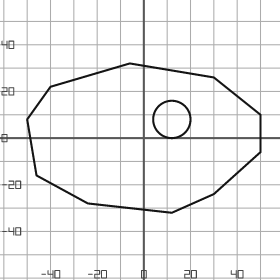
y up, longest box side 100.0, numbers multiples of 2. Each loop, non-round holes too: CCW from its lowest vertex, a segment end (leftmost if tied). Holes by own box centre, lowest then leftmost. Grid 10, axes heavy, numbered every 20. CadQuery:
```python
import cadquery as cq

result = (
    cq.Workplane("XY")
    .moveTo(12.0, -32.0)
    .lineTo(30.0, -24.0)
    .lineTo(50.0, -6.0)
    .lineTo(50.0, 10.0)
    .lineTo(30.0, 26.0)
    .lineTo(-6.0, 32.0)
    .lineTo(-40.0, 22.0)
    .lineTo(-50.0, 8.0)
    .lineTo(-46.0, -16.0)
    .lineTo(-24.0, -28.0)
    .close()
    .moveTo(12.0, 8.0)
    .circle(8.0)
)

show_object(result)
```